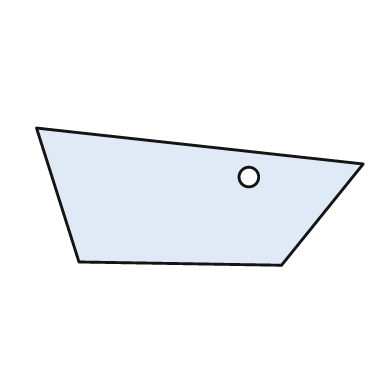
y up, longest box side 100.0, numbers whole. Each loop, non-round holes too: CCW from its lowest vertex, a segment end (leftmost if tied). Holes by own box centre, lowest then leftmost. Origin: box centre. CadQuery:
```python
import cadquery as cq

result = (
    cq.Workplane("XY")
    .moveTo(25.0, -21.0)
    .lineTo(50.0, 10.0)
    .lineTo(-50.0, 21.0)
    .lineTo(-37.0, -20.0)
    .close()
    .moveTo(15.0, 6.0)
    .circle(3.0)
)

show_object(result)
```